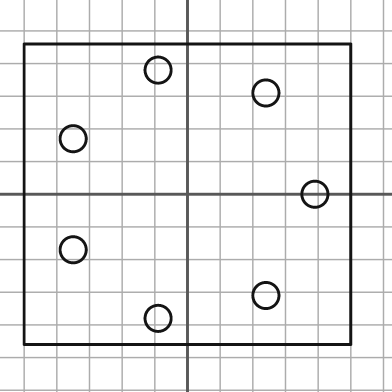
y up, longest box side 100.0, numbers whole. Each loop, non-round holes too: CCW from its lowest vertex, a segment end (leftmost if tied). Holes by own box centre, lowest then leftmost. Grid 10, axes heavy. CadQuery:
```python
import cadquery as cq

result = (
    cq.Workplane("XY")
    .moveTo(-50.0, -46.0)
    .lineTo(50.0, -46.0)
    .lineTo(50.0, 46.0)
    .lineTo(-50.0, 46.0)
    .close()
    .moveTo(-9.0, -38.0)
    .circle(4.0)
    .moveTo(24.0, -31.0)
    .circle(4.0)
    .moveTo(-35.0, -17.0)
    .circle(4.0)
    .moveTo(39.0, 0.0)
    .circle(4.0)
    .moveTo(-35.0, 17.0)
    .circle(4.0)
    .moveTo(24.0, 31.0)
    .circle(4.0)
    .moveTo(-9.0, 38.0)
    .circle(4.0)
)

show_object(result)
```